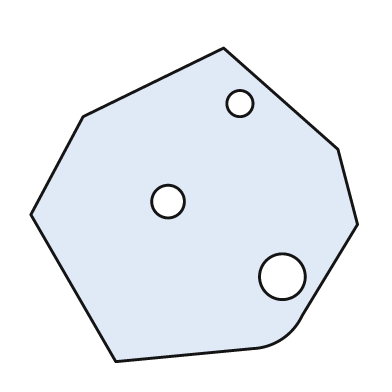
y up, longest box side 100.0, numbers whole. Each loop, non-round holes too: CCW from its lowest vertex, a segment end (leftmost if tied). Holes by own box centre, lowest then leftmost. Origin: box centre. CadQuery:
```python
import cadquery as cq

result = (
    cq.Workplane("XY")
    .moveTo(-24.0, -48.0)
    .lineTo(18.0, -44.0)
    .threePointArc((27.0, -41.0), (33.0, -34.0))
    .lineTo(50.0, -6.0)
    .lineTo(44.0, 17.0)
    .lineTo(9.0, 48.0)
    .lineTo(-34.0, 27.0)
    .lineTo(-50.0, -3.0)
    .close()
    .moveTo(27.0, -22.0)
    .circle(7.0)
    .moveTo(-8.0, 1.0)
    .circle(5.0)
    .moveTo(14.0, 31.0)
    .circle(4.0)
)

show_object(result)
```